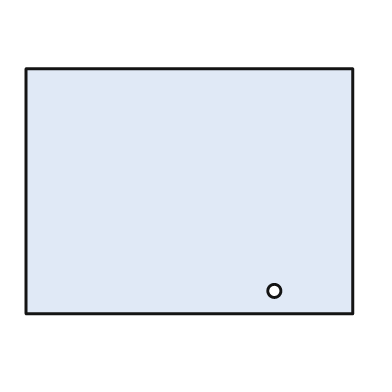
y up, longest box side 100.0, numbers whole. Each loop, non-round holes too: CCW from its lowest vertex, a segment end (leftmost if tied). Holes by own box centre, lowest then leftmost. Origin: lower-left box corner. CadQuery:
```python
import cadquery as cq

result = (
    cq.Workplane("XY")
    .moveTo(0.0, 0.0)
    .lineTo(100.0, 0.0)
    .lineTo(100.0, 75.0)
    .lineTo(0.0, 75.0)
    .close()
    .moveTo(76.0, 7.0)
    .circle(2.0)
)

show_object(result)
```